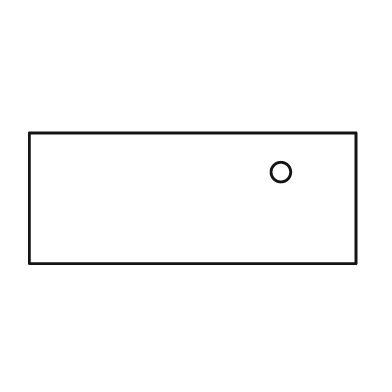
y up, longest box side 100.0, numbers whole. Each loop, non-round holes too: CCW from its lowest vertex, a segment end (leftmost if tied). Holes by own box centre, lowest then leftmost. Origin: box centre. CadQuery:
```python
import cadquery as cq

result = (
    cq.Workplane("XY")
    .moveTo(-50.0, -20.0)
    .lineTo(50.0, -20.0)
    .lineTo(50.0, 20.0)
    .lineTo(-50.0, 20.0)
    .close()
    .moveTo(27.0, 8.0)
    .circle(3.0)
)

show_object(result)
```